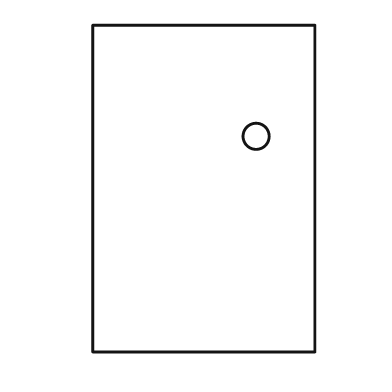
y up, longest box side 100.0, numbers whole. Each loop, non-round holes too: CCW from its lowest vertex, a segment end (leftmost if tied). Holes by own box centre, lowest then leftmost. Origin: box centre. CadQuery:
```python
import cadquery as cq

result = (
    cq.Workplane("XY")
    .moveTo(-34.0, -50.0)
    .lineTo(34.0, -50.0)
    .lineTo(34.0, 50.0)
    .lineTo(-34.0, 50.0)
    .close()
    .moveTo(16.0, 16.0)
    .circle(4.0)
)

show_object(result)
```